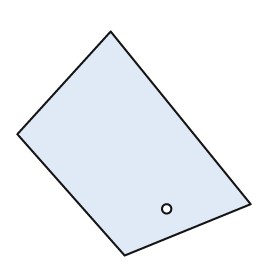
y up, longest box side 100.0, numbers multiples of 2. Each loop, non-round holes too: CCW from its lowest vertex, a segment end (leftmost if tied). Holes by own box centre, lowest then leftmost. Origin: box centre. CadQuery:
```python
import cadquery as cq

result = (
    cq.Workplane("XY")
    .moveTo(-4.0, -48.0)
    .lineTo(50.0, -26.0)
    .lineTo(-10.0, 48.0)
    .lineTo(-50.0, 4.0)
    .close()
    .moveTo(14.0, -28.0)
    .circle(2.0)
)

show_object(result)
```